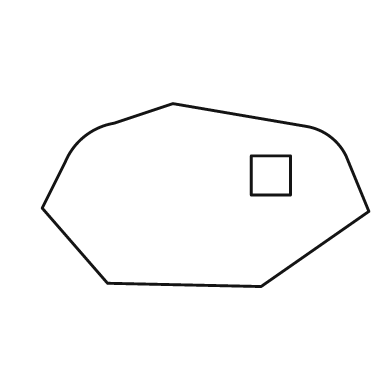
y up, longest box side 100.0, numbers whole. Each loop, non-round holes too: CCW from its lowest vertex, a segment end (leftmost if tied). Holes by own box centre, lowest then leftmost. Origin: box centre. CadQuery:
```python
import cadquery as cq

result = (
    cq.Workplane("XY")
    .moveTo(17.0, -28.0)
    .lineTo(50.0, -5.0)
    .lineTo(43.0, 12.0)
    .threePointArc((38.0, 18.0), (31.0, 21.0))
    .lineTo(-10.0, 28.0)
    .lineTo(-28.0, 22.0)
    .threePointArc((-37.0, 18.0), (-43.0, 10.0))
    .lineTo(-50.0, -4.0)
    .lineTo(-30.0, -27.0)
    .close()
    .moveTo(14.0, 0.0)
    .lineTo(26.0, 0.0)
    .lineTo(26.0, 12.0)
    .lineTo(14.0, 12.0)
    .close()
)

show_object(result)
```